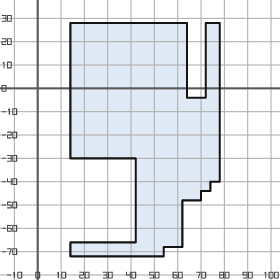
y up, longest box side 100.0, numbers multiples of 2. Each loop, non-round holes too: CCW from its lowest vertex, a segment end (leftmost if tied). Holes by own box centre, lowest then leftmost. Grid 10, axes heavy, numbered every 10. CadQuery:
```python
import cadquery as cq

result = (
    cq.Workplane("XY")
    .moveTo(14.0, -72.0)
    .lineTo(54.0, -72.0)
    .lineTo(54.0, -68.0)
    .lineTo(62.0, -68.0)
    .lineTo(62.0, -48.0)
    .lineTo(70.0, -48.0)
    .lineTo(70.0, -44.0)
    .lineTo(74.0, -44.0)
    .lineTo(74.0, -40.0)
    .lineTo(78.0, -40.0)
    .lineTo(78.0, 28.0)
    .lineTo(72.0, 28.0)
    .lineTo(72.0, -4.0)
    .lineTo(64.0, -4.0)
    .lineTo(64.0, 28.0)
    .lineTo(14.0, 28.0)
    .lineTo(14.0, -30.0)
    .lineTo(42.0, -30.0)
    .lineTo(42.0, -66.0)
    .lineTo(14.0, -66.0)
    .close()
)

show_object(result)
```